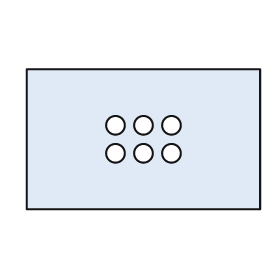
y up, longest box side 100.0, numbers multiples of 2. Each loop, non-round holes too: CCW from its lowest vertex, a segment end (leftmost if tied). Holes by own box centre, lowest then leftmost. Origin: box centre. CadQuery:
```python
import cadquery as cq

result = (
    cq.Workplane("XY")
    .moveTo(-50.0, -30.0)
    .lineTo(50.0, -30.0)
    .lineTo(50.0, 30.0)
    .lineTo(-50.0, 30.0)
    .close()
    .moveTo(-12.0, -6.0)
    .circle(4.0)
    .moveTo(0.0, -6.0)
    .circle(4.0)
    .moveTo(12.0, -6.0)
    .circle(4.0)
    .moveTo(-12.0, 6.0)
    .circle(4.0)
    .moveTo(0.0, 6.0)
    .circle(4.0)
    .moveTo(12.0, 6.0)
    .circle(4.0)
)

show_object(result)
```